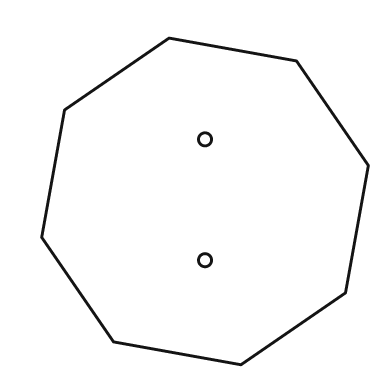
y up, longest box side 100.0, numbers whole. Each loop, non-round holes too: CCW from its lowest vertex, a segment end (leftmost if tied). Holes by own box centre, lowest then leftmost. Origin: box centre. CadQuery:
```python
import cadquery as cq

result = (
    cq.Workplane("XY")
    .moveTo(11.0, -50.0)
    .lineTo(43.0, -28.0)
    .lineTo(50.0, 11.0)
    .lineTo(28.0, 43.0)
    .lineTo(-11.0, 50.0)
    .lineTo(-43.0, 28.0)
    .lineTo(-50.0, -11.0)
    .lineTo(-28.0, -43.0)
    .close()
    .moveTo(0.0, -18.0)
    .circle(2.0)
    .moveTo(0.0, 19.0)
    .circle(2.0)
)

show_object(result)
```